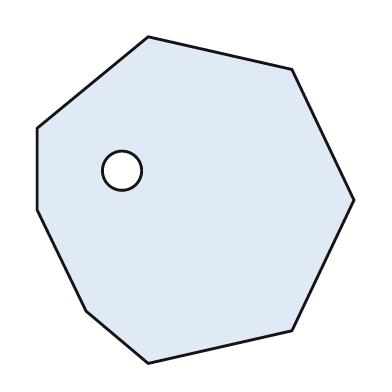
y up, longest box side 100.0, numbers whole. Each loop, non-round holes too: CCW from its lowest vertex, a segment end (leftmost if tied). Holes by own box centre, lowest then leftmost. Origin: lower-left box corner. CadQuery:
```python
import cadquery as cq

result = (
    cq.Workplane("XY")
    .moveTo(34.0, 0.0)
    .lineTo(78.0, 10.0)
    .lineTo(97.0, 50.0)
    .lineTo(78.0, 90.0)
    .lineTo(34.0, 100.0)
    .lineTo(0.0, 72.0)
    .lineTo(0.0, 47.0)
    .lineTo(15.0, 16.0)
    .close()
    .moveTo(26.0, 59.0)
    .circle(6.0)
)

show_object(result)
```